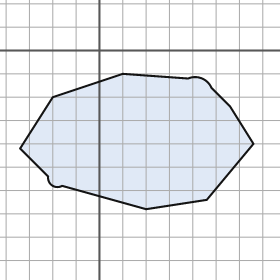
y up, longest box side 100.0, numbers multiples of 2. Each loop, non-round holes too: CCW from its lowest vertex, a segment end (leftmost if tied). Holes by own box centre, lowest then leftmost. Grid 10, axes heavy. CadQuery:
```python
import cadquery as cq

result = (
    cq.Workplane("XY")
    .moveTo(20.0, -68.0)
    .lineTo(46.0, -64.0)
    .lineTo(66.0, -40.0)
    .lineTo(56.0, -24.0)
    .lineTo(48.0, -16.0)
    .threePointArc((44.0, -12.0), (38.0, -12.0))
    .lineTo(10.0, -10.0)
    .lineTo(-20.0, -20.0)
    .lineTo(-34.0, -42.0)
    .lineTo(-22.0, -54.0)
    .threePointArc((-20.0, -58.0), (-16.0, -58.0))
    .close()
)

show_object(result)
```